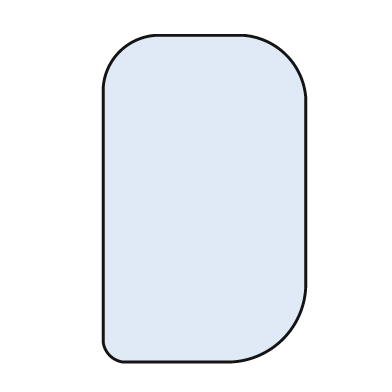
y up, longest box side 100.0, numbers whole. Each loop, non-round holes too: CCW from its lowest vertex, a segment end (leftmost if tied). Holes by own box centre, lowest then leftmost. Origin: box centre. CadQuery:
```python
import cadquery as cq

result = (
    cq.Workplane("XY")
    .moveTo(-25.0, -50.0)
    .lineTo(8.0, -50.0)
    .threePointArc((24.0, -43.0), (31.0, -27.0))
    .lineTo(31.0, 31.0)
    .threePointArc((25.0, 44.0), (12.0, 50.0))
    .lineTo(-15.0, 50.0)
    .threePointArc((-26.0, 45.0), (-31.0, 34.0))
    .lineTo(-31.0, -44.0)
    .threePointArc((-29.0, -48.0), (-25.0, -50.0))
    .close()
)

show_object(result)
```